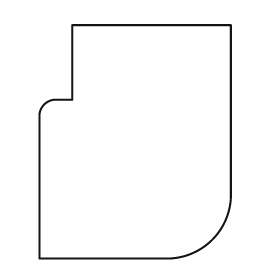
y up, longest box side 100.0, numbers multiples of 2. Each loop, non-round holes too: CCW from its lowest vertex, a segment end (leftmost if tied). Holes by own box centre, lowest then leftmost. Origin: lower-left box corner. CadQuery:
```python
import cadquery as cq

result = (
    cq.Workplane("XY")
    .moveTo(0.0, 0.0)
    .lineTo(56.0, 0.0)
    .threePointArc((74.0, 8.0), (82.0, 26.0))
    .lineTo(82.0, 100.0)
    .lineTo(14.0, 100.0)
    .lineTo(14.0, 68.0)
    .lineTo(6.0, 68.0)
    .threePointArc((2.0, 66.0), (0.0, 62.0))
    .close()
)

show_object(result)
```